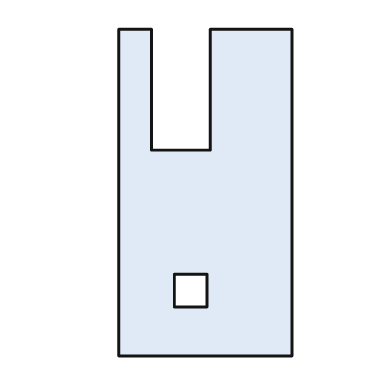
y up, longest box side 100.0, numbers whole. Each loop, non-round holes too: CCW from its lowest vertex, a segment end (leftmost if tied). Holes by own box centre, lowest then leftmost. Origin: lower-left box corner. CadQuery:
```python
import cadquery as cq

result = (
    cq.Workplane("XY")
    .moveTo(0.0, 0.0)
    .lineTo(53.0, 0.0)
    .lineTo(53.0, 100.0)
    .lineTo(28.0, 100.0)
    .lineTo(28.0, 63.0)
    .lineTo(10.0, 63.0)
    .lineTo(10.0, 100.0)
    .lineTo(0.0, 100.0)
    .close()
    .moveTo(17.0, 15.0)
    .lineTo(27.0, 15.0)
    .lineTo(27.0, 25.0)
    .lineTo(17.0, 25.0)
    .close()
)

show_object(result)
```